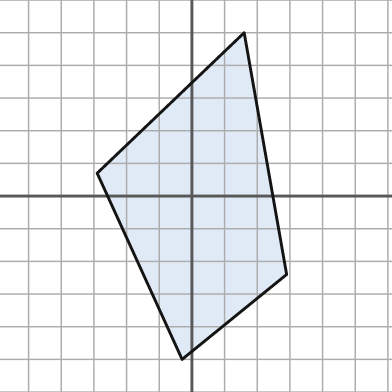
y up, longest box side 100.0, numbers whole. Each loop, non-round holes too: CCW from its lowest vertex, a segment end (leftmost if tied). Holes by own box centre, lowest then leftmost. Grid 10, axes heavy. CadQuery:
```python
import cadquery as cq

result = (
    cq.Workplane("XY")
    .moveTo(-3.0, -50.0)
    .lineTo(29.0, -24.0)
    .lineTo(16.0, 50.0)
    .lineTo(-29.0, 7.0)
    .close()
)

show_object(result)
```